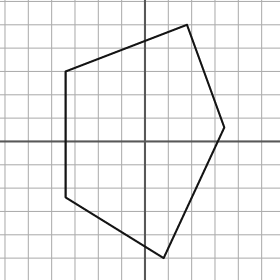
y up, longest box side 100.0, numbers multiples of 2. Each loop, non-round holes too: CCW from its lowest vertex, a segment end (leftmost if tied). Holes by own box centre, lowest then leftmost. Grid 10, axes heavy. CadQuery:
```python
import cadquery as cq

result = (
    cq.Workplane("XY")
    .moveTo(8.0, -50.0)
    .lineTo(34.0, 6.0)
    .lineTo(18.0, 50.0)
    .lineTo(-34.0, 30.0)
    .lineTo(-34.0, -24.0)
    .close()
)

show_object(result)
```